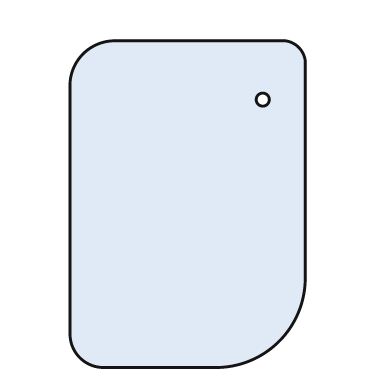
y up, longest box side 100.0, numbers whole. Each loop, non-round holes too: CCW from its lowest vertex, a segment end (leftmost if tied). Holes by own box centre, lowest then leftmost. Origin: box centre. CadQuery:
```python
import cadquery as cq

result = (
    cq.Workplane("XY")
    .moveTo(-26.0, -50.0)
    .lineTo(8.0, -50.0)
    .threePointArc((28.0, -42.0), (36.0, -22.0))
    .lineTo(36.0, 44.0)
    .threePointArc((34.0, 48.0), (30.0, 50.0))
    .lineTo(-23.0, 50.0)
    .threePointArc((-32.0, 46.0), (-36.0, 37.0))
    .lineTo(-36.0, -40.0)
    .threePointArc((-33.0, -47.0), (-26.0, -50.0))
    .close()
    .moveTo(23.0, 32.0)
    .circle(2.0)
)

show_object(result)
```